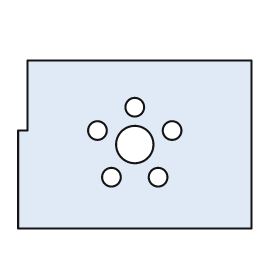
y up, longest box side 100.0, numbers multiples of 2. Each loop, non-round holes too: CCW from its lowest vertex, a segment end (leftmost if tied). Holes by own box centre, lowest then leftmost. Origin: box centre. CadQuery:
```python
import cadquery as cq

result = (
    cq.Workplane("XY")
    .moveTo(-50.0, -36.0)
    .lineTo(50.0, -36.0)
    .lineTo(50.0, 36.0)
    .lineTo(-46.0, 36.0)
    .lineTo(-46.0, 6.0)
    .lineTo(-50.0, 6.0)
    .close()
    .moveTo(-10.0, -14.0)
    .circle(4.0)
    .moveTo(10.0, -14.0)
    .circle(4.0)
    .moveTo(0.0, 0.0)
    .circle(8.0)
    .moveTo(-16.0, 6.0)
    .circle(4.0)
    .moveTo(16.0, 6.0)
    .circle(4.0)
    .moveTo(0.0, 16.0)
    .circle(4.0)
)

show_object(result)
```